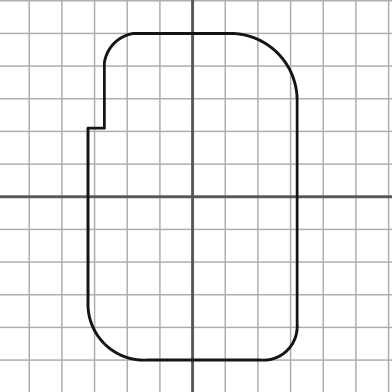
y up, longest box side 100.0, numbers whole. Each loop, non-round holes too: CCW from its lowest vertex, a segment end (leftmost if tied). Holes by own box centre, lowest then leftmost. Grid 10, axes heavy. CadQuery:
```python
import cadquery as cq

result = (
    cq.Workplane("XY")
    .moveTo(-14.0, -50.0)
    .lineTo(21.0, -50.0)
    .threePointArc((29.0, -47.0), (32.0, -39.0))
    .lineTo(32.0, 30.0)
    .threePointArc((26.0, 44.0), (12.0, 50.0))
    .lineTo(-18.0, 50.0)
    .threePointArc((-24.0, 47.0), (-27.0, 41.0))
    .lineTo(-27.0, 21.0)
    .lineTo(-32.0, 21.0)
    .lineTo(-32.0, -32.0)
    .threePointArc((-27.0, -45.0), (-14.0, -50.0))
    .close()
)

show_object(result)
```